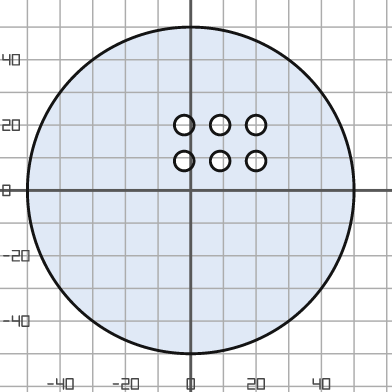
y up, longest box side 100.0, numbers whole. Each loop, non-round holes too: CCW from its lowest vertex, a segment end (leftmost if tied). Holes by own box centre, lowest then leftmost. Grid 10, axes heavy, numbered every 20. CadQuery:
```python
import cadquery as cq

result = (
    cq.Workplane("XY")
    .moveTo(0.0, 0.0)
    .circle(50.0)
    .moveTo(-2.0, 9.0)
    .circle(3.0)
    .moveTo(9.0, 9.0)
    .circle(3.0)
    .moveTo(20.0, 9.0)
    .circle(3.0)
    .moveTo(-2.0, 20.0)
    .circle(3.0)
    .moveTo(9.0, 20.0)
    .circle(3.0)
    .moveTo(20.0, 20.0)
    .circle(3.0)
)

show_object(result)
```